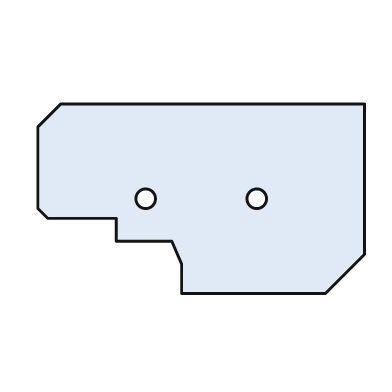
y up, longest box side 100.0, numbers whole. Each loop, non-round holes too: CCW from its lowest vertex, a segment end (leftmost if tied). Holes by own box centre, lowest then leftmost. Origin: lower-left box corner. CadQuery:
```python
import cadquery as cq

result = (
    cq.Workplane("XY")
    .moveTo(44.0, 0.0)
    .lineTo(88.0, 0.0)
    .lineTo(100.0, 12.0)
    .lineTo(100.0, 58.0)
    .lineTo(7.0, 58.0)
    .lineTo(0.0, 51.0)
    .lineTo(0.0, 26.0)
    .lineTo(3.0, 23.0)
    .lineTo(24.0, 23.0)
    .lineTo(24.0, 16.0)
    .lineTo(41.0, 16.0)
    .lineTo(44.0, 9.0)
    .close()
    .moveTo(33.0, 29.0)
    .circle(3.0)
    .moveTo(67.0, 29.0)
    .circle(3.0)
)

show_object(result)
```